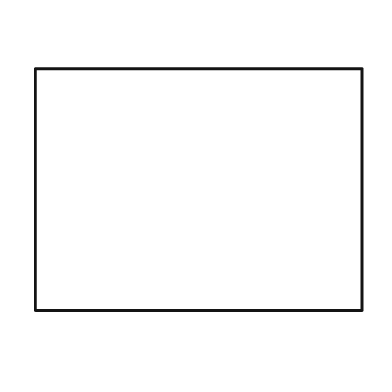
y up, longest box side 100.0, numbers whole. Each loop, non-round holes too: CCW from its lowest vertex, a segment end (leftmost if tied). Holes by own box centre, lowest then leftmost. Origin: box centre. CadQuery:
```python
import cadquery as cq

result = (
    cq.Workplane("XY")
    .moveTo(-50.0, -37.0)
    .lineTo(50.0, -37.0)
    .lineTo(50.0, 37.0)
    .lineTo(-50.0, 37.0)
    .close()
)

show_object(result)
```